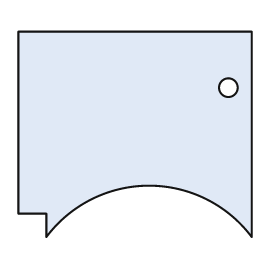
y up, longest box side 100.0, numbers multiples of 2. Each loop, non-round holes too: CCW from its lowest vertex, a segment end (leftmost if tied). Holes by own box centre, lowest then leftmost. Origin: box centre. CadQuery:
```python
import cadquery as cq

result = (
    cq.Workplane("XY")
    .moveTo(-38.0, -44.0)
    .threePointArc((6.0, -22.0), (50.0, -44.0))
    .lineTo(50.0, 44.0)
    .lineTo(-50.0, 44.0)
    .lineTo(-50.0, -34.0)
    .lineTo(-38.0, -34.0)
    .close()
    .moveTo(40.0, 20.0)
    .circle(4.0)
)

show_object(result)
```